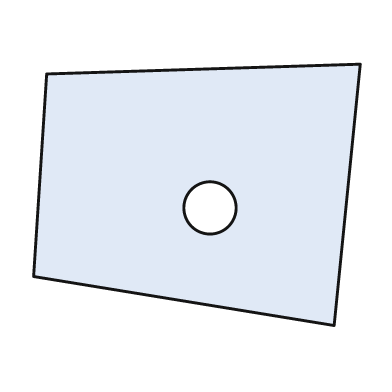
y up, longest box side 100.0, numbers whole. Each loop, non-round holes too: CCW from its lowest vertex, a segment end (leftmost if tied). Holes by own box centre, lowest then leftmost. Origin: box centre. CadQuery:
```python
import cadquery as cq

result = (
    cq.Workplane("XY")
    .moveTo(42.0, -40.0)
    .lineTo(50.0, 40.0)
    .lineTo(-46.0, 37.0)
    .lineTo(-50.0, -25.0)
    .close()
    .moveTo(4.0, -4.0)
    .circle(8.0)
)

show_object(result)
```